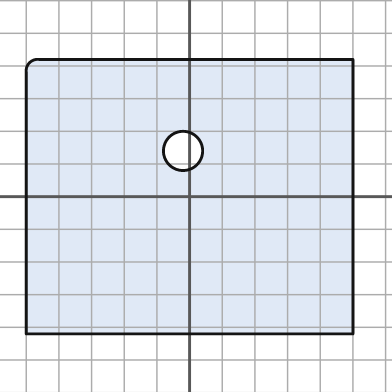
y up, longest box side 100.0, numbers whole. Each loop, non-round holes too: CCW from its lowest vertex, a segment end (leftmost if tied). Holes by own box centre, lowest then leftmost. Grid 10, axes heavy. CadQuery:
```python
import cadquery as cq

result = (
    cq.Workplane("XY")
    .moveTo(-50.0, -42.0)
    .lineTo(50.0, -42.0)
    .lineTo(50.0, 42.0)
    .lineTo(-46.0, 42.0)
    .threePointArc((-49.0, 41.0), (-50.0, 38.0))
    .close()
    .moveTo(-2.0, 14.0)
    .circle(6.0)
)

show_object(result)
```